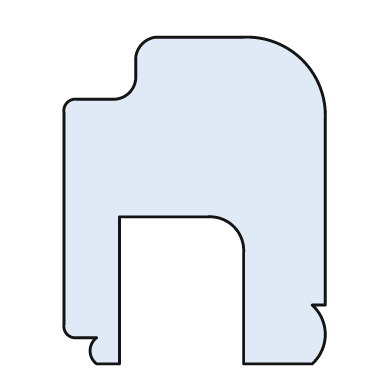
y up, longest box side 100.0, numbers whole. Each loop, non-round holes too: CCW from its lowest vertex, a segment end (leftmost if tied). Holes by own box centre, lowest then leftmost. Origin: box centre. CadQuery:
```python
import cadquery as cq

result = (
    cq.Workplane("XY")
    .moveTo(-30.0, -50.0)
    .lineTo(-23.0, -50.0)
    .lineTo(-23.0, -5.0)
    .lineTo(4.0, -5.0)
    .threePointArc((12.0, -8.0), (15.0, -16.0))
    .lineTo(15.0, -50.0)
    .lineTo(36.0, -50.0)
    .threePointArc((40.0, -41.0), (36.0, -32.0))
    .lineTo(40.0, -32.0)
    .lineTo(40.0, 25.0)
    .threePointArc((33.0, 43.0), (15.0, 50.0))
    .lineTo(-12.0, 50.0)
    .threePointArc((-16.0, 48.0), (-18.0, 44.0))
    .lineTo(-18.0, 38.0)
    .threePointArc((-20.0, 33.0), (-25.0, 31.0))
    .lineTo(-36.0, 31.0)
    .threePointArc((-39.0, 30.0), (-40.0, 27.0))
    .lineTo(-40.0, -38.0)
    .threePointArc((-39.0, -41.0), (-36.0, -42.0))
    .lineTo(-30.0, -42.0)
    .threePointArc((-32.0, -46.0), (-30.0, -50.0))
    .close()
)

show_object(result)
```